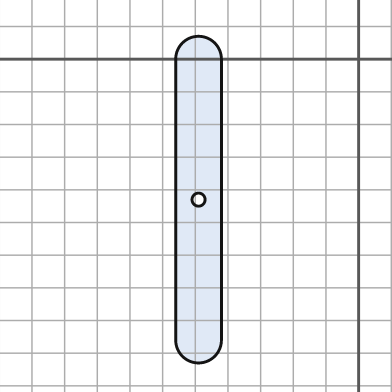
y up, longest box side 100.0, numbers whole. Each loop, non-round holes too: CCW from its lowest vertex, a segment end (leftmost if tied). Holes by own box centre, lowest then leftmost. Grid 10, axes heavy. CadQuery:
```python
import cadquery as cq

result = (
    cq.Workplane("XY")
    .moveTo(-56.0, -86.0)
    .threePointArc((-49.0, -93.0), (-42.0, -86.0))
    .lineTo(-42.0, 0.0)
    .threePointArc((-49.0, 7.0), (-56.0, 0.0))
    .close()
    .moveTo(-49.0, -43.0)
    .circle(2.0)
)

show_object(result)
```